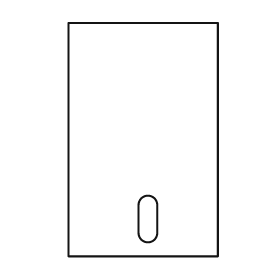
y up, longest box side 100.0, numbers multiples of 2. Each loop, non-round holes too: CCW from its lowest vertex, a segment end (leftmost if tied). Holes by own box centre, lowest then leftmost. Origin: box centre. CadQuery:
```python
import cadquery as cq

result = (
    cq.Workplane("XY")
    .moveTo(-32.0, -50.0)
    .lineTo(32.0, -50.0)
    .lineTo(32.0, 50.0)
    .lineTo(-32.0, 50.0)
    .close()
    .moveTo(-2.0, -40.0)
    .threePointArc((2.0, -44.0), (6.0, -40.0))
    .lineTo(6.0, -28.0)
    .threePointArc((2.0, -24.0), (-2.0, -28.0))
    .close()
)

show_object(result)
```